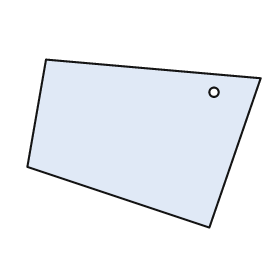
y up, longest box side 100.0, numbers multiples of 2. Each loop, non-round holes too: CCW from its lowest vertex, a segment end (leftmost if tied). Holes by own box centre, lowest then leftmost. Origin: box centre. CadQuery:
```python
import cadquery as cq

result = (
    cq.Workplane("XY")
    .moveTo(28.0, -36.0)
    .lineTo(50.0, 28.0)
    .lineTo(-42.0, 36.0)
    .lineTo(-50.0, -10.0)
    .close()
    .moveTo(30.0, 22.0)
    .circle(2.0)
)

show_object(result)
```